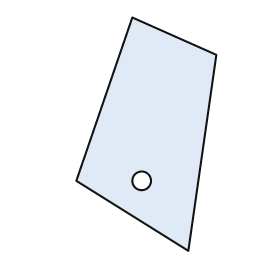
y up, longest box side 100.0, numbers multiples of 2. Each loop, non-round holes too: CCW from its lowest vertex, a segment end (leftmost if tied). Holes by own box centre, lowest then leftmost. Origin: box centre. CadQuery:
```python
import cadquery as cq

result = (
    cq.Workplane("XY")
    .moveTo(18.0, -50.0)
    .lineTo(30.0, 34.0)
    .lineTo(-6.0, 50.0)
    .lineTo(-30.0, -20.0)
    .close()
    .moveTo(-2.0, -20.0)
    .circle(4.0)
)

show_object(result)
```